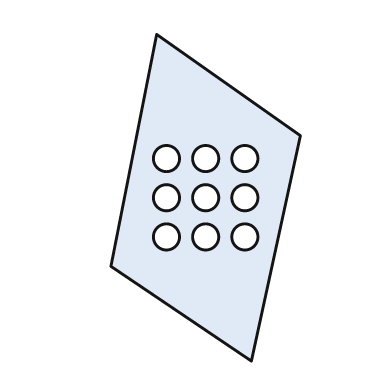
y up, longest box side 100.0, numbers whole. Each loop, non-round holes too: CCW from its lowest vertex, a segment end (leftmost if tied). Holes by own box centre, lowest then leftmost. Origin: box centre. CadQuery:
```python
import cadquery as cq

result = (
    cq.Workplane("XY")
    .moveTo(14.0, -50.0)
    .lineTo(29.0, 19.0)
    .lineTo(-15.0, 50.0)
    .lineTo(-29.0, -21.0)
    .close()
    .moveTo(-12.0, -12.0)
    .circle(4.0)
    .moveTo(0.0, -12.0)
    .circle(4.0)
    .moveTo(12.0, -12.0)
    .circle(4.0)
    .moveTo(-12.0, 0.0)
    .circle(4.0)
    .moveTo(0.0, 0.0)
    .circle(4.0)
    .moveTo(12.0, 0.0)
    .circle(4.0)
    .moveTo(-12.0, 12.0)
    .circle(4.0)
    .moveTo(0.0, 12.0)
    .circle(4.0)
    .moveTo(12.0, 12.0)
    .circle(4.0)
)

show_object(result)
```